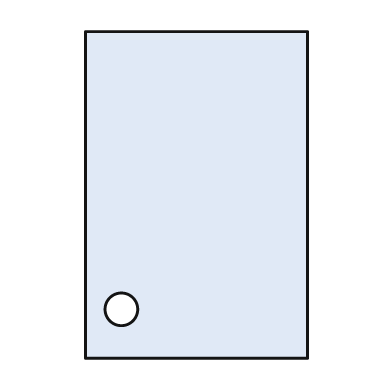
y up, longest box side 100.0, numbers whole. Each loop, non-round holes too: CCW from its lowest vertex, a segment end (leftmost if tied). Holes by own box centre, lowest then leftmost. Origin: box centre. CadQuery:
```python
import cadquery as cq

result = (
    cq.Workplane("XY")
    .moveTo(-34.0, -50.0)
    .lineTo(34.0, -50.0)
    .lineTo(34.0, 50.0)
    .lineTo(-34.0, 50.0)
    .close()
    .moveTo(-23.0, -35.0)
    .circle(5.0)
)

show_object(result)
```